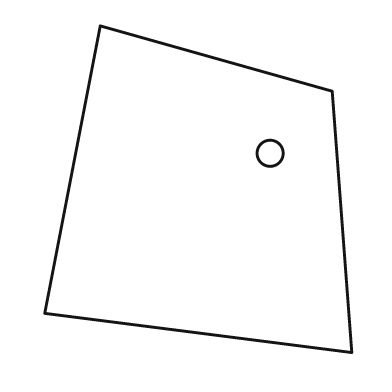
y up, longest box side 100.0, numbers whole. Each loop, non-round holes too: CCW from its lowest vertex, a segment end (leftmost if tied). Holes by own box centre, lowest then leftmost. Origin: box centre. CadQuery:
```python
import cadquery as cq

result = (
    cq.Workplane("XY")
    .moveTo(47.0, -50.0)
    .lineTo(41.0, 30.0)
    .lineTo(-30.0, 50.0)
    .lineTo(-47.0, -38.0)
    .close()
    .moveTo(22.0, 11.0)
    .circle(4.0)
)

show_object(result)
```